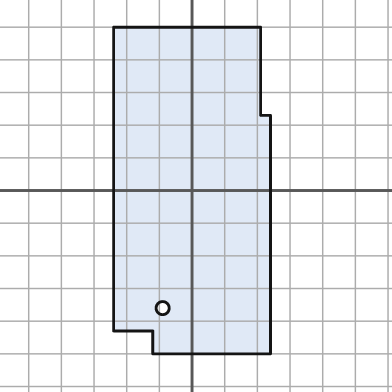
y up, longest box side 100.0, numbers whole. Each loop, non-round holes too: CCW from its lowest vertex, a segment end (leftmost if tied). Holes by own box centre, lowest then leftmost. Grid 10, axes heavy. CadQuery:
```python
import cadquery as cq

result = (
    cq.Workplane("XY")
    .moveTo(-12.0, -50.0)
    .lineTo(24.0, -50.0)
    .lineTo(24.0, 23.0)
    .lineTo(21.0, 23.0)
    .lineTo(21.0, 50.0)
    .lineTo(-24.0, 50.0)
    .lineTo(-24.0, -43.0)
    .lineTo(-12.0, -43.0)
    .close()
    .moveTo(-9.0, -36.0)
    .circle(2.0)
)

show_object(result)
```